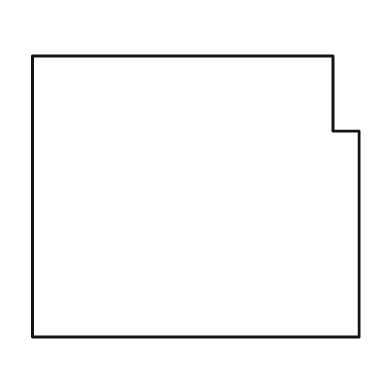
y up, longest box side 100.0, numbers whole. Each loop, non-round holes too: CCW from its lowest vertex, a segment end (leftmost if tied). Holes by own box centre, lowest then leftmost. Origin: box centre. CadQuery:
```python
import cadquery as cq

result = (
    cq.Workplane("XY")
    .moveTo(-50.0, -43.0)
    .lineTo(50.0, -43.0)
    .lineTo(50.0, 20.0)
    .lineTo(42.0, 20.0)
    .lineTo(42.0, 43.0)
    .lineTo(-50.0, 43.0)
    .close()
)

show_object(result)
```